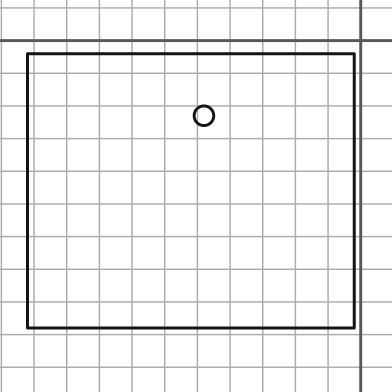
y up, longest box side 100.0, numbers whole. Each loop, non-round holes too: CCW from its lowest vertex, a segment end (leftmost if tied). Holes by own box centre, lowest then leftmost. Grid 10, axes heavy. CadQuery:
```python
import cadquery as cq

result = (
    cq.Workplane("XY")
    .moveTo(-102.0, -88.0)
    .lineTo(-2.0, -88.0)
    .lineTo(-2.0, -4.0)
    .lineTo(-102.0, -4.0)
    .close()
    .moveTo(-48.0, -23.0)
    .circle(3.0)
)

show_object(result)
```